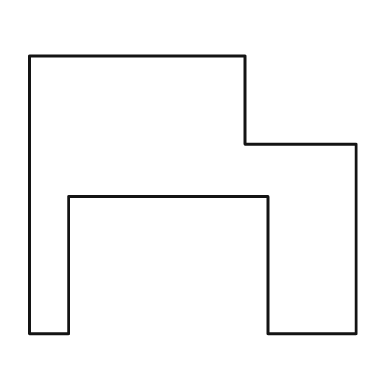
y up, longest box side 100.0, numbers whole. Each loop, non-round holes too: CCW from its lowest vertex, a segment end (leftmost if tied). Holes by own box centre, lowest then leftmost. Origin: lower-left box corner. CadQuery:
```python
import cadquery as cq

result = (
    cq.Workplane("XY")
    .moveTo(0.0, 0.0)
    .lineTo(12.0, 0.0)
    .lineTo(12.0, 42.0)
    .lineTo(73.0, 42.0)
    .lineTo(73.0, 0.0)
    .lineTo(100.0, 0.0)
    .lineTo(100.0, 58.0)
    .lineTo(66.0, 58.0)
    .lineTo(66.0, 85.0)
    .lineTo(0.0, 85.0)
    .close()
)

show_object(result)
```